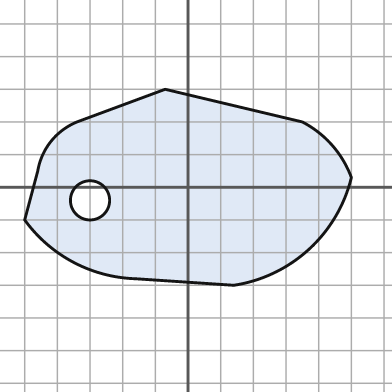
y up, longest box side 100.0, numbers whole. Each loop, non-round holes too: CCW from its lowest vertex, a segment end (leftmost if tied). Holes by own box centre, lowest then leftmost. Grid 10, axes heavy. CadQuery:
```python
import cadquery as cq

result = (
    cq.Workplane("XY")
    .moveTo(14.0, -30.0)
    .threePointArc((37.0, -19.0), (50.0, 3.0))
    .threePointArc((44.0, 13.0), (35.0, 20.0))
    .lineTo(-7.0, 30.0)
    .lineTo(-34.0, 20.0)
    .threePointArc((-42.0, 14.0), (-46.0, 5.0))
    .lineTo(-50.0, -10.0)
    .threePointArc((-35.0, -23.0), (-16.0, -28.0))
    .close()
    .moveTo(-30.0, -4.0)
    .circle(6.0)
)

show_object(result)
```